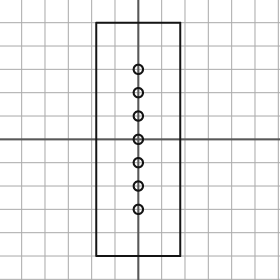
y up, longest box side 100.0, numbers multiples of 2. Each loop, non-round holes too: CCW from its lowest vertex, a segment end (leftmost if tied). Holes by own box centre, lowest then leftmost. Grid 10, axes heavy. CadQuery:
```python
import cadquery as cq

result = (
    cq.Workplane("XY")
    .moveTo(-18.0, -50.0)
    .lineTo(18.0, -50.0)
    .lineTo(18.0, 50.0)
    .lineTo(-18.0, 50.0)
    .close()
    .moveTo(0.0, -30.0)
    .circle(2.0)
    .moveTo(0.0, -20.0)
    .circle(2.0)
    .moveTo(0.0, -10.0)
    .circle(2.0)
    .moveTo(0.0, 0.0)
    .circle(2.0)
    .moveTo(0.0, 10.0)
    .circle(2.0)
    .moveTo(0.0, 20.0)
    .circle(2.0)
    .moveTo(0.0, 30.0)
    .circle(2.0)
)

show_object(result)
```